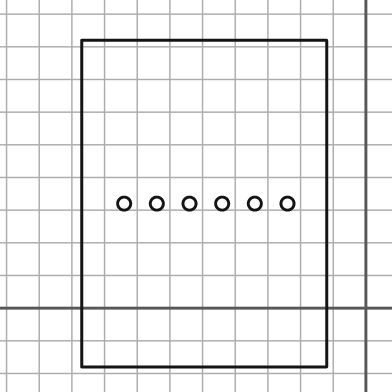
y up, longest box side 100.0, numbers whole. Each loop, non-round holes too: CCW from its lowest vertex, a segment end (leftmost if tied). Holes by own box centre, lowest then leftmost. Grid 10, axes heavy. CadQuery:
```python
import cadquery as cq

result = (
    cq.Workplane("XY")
    .moveTo(-87.0, -18.0)
    .lineTo(-12.0, -18.0)
    .lineTo(-12.0, 82.0)
    .lineTo(-87.0, 82.0)
    .close()
    .moveTo(-74.0, 32.0)
    .circle(2.0)
    .moveTo(-64.0, 32.0)
    .circle(2.0)
    .moveTo(-54.0, 32.0)
    .circle(2.0)
    .moveTo(-44.0, 32.0)
    .circle(2.0)
    .moveTo(-34.0, 32.0)
    .circle(2.0)
    .moveTo(-24.0, 32.0)
    .circle(2.0)
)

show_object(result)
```